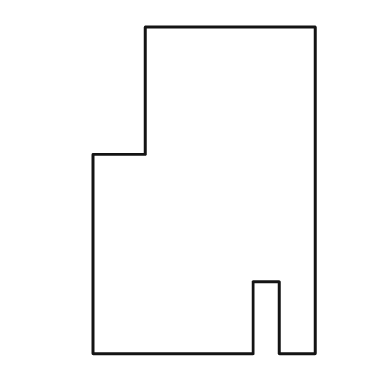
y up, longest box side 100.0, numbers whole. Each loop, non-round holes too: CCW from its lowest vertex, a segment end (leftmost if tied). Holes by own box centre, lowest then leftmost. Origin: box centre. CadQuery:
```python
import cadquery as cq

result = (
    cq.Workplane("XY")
    .moveTo(-34.0, -50.0)
    .lineTo(15.0, -50.0)
    .lineTo(15.0, -28.0)
    .lineTo(23.0, -28.0)
    .lineTo(23.0, -50.0)
    .lineTo(34.0, -50.0)
    .lineTo(34.0, 50.0)
    .lineTo(-18.0, 50.0)
    .lineTo(-18.0, 11.0)
    .lineTo(-34.0, 11.0)
    .close()
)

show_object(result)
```